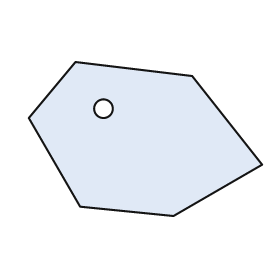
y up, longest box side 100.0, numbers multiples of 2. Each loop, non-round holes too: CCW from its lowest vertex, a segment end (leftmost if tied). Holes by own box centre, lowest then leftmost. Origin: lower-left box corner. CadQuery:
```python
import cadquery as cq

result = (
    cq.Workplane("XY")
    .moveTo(62.0, 0.0)
    .lineTo(100.0, 22.0)
    .lineTo(70.0, 60.0)
    .lineTo(20.0, 66.0)
    .lineTo(0.0, 42.0)
    .lineTo(22.0, 4.0)
    .close()
    .moveTo(32.0, 46.0)
    .circle(4.0)
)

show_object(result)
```